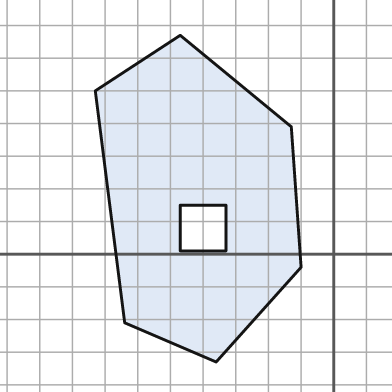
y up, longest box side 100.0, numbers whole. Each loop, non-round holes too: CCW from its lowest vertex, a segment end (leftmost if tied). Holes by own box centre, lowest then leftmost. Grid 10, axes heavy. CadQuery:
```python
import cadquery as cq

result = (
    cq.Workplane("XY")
    .moveTo(-36.0, -33.0)
    .lineTo(-10.0, -4.0)
    .lineTo(-13.0, 39.0)
    .lineTo(-47.0, 67.0)
    .lineTo(-73.0, 50.0)
    .lineTo(-64.0, -21.0)
    .close()
    .moveTo(-47.0, 1.0)
    .lineTo(-33.0, 1.0)
    .lineTo(-33.0, 15.0)
    .lineTo(-47.0, 15.0)
    .close()
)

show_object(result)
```